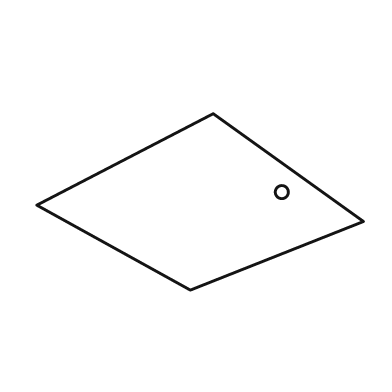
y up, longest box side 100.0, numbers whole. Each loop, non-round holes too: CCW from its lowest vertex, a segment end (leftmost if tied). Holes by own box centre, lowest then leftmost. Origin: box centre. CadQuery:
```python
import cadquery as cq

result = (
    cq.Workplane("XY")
    .moveTo(-3.0, -27.0)
    .lineTo(50.0, -6.0)
    .lineTo(4.0, 27.0)
    .lineTo(-50.0, -1.0)
    .close()
    .moveTo(25.0, 3.0)
    .circle(2.0)
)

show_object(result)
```